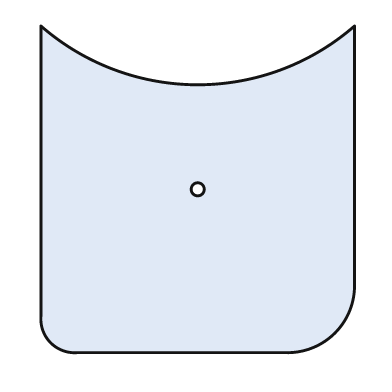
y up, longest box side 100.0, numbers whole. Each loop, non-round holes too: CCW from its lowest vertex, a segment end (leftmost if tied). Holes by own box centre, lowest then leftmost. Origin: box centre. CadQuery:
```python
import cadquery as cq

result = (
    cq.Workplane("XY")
    .moveTo(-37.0, -50.0)
    .lineTo(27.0, -50.0)
    .threePointArc((42.0, -44.0), (48.0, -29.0))
    .lineTo(48.0, 50.0)
    .threePointArc((0.0, 32.0), (-48.0, 50.0))
    .lineTo(-48.0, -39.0)
    .threePointArc((-45.0, -47.0), (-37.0, -50.0))
    .close()
    .moveTo(0.0, 0.0)
    .circle(2.0)
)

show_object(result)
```